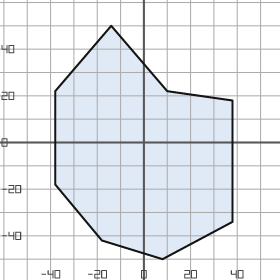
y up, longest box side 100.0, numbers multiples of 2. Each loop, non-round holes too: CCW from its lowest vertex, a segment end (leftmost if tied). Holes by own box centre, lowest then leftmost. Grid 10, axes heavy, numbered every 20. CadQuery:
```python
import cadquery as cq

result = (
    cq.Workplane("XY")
    .moveTo(8.0, -50.0)
    .lineTo(38.0, -34.0)
    .lineTo(38.0, 18.0)
    .lineTo(10.0, 22.0)
    .lineTo(-14.0, 50.0)
    .lineTo(-38.0, 22.0)
    .lineTo(-38.0, -18.0)
    .lineTo(-18.0, -42.0)
    .close()
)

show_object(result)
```